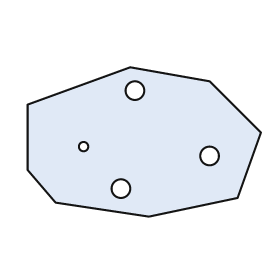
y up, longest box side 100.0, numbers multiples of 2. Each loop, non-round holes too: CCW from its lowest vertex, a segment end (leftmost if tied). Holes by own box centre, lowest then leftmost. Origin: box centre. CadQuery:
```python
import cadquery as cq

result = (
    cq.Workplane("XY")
    .moveTo(2.0, -32.0)
    .lineTo(40.0, -24.0)
    .lineTo(50.0, 4.0)
    .lineTo(28.0, 26.0)
    .lineTo(-6.0, 32.0)
    .lineTo(-50.0, 16.0)
    .lineTo(-50.0, -12.0)
    .lineTo(-38.0, -26.0)
    .close()
    .moveTo(-10.0, -20.0)
    .circle(4.0)
    .moveTo(28.0, -6.0)
    .circle(4.0)
    .moveTo(-26.0, -2.0)
    .circle(2.0)
    .moveTo(-4.0, 22.0)
    .circle(4.0)
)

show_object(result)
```